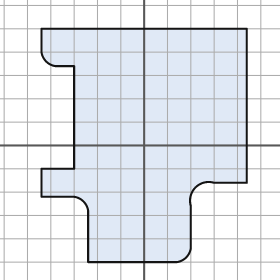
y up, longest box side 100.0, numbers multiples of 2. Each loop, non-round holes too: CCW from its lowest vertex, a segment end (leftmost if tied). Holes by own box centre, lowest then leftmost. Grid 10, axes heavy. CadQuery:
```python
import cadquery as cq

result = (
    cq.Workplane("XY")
    .moveTo(-24.0, -50.0)
    .lineTo(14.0, -50.0)
    .threePointArc((18.0, -48.0), (20.0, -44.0))
    .lineTo(20.0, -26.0)
    .threePointArc((22.0, -18.0), (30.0, -16.0))
    .lineTo(44.0, -16.0)
    .lineTo(44.0, 50.0)
    .lineTo(-44.0, 50.0)
    .lineTo(-44.0, 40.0)
    .threePointArc((-42.0, 36.0), (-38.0, 34.0))
    .lineTo(-30.0, 34.0)
    .lineTo(-30.0, -10.0)
    .lineTo(-44.0, -10.0)
    .lineTo(-44.0, -22.0)
    .lineTo(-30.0, -22.0)
    .threePointArc((-26.0, -24.0), (-24.0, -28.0))
    .close()
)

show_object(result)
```